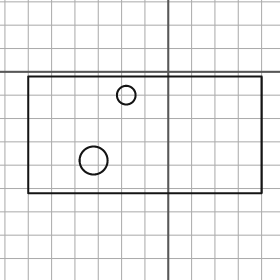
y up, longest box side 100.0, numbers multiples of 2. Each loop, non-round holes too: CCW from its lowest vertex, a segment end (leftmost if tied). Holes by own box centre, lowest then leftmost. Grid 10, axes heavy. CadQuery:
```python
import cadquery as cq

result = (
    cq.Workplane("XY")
    .moveTo(-60.0, -52.0)
    .lineTo(40.0, -52.0)
    .lineTo(40.0, -2.0)
    .lineTo(-60.0, -2.0)
    .close()
    .moveTo(-32.0, -38.0)
    .circle(6.0)
    .moveTo(-18.0, -10.0)
    .circle(4.0)
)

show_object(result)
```